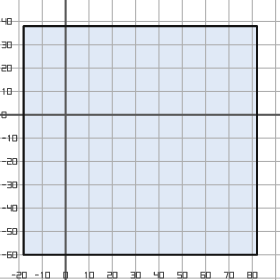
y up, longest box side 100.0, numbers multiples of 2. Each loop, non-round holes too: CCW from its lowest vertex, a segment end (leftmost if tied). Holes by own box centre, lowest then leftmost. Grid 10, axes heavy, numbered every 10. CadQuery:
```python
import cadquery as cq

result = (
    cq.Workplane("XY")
    .moveTo(-18.0, -60.0)
    .lineTo(82.0, -60.0)
    .lineTo(82.0, 38.0)
    .lineTo(-18.0, 38.0)
    .close()
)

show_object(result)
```